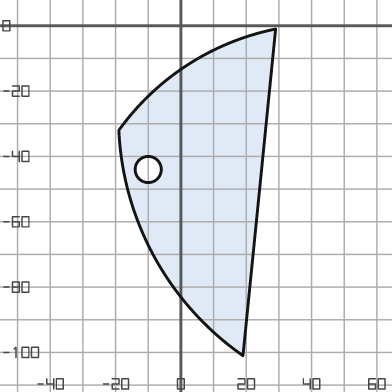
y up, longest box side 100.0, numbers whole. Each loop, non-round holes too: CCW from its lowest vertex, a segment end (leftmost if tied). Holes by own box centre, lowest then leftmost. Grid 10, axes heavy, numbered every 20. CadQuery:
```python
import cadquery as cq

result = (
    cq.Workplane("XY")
    .moveTo(19.0, -101.0)
    .lineTo(29.0, -1.0)
    .threePointArc((2.0, -12.0), (-19.0, -32.0))
    .threePointArc((-8.0, -71.0), (19.0, -101.0))
    .close()
    .moveTo(-10.0, -44.0)
    .circle(4.0)
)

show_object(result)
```